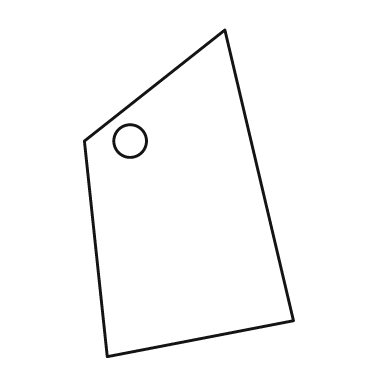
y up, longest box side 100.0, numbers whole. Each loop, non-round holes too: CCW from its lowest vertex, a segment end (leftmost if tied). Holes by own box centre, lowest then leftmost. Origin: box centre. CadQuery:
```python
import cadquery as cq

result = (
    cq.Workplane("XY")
    .moveTo(-25.0, -50.0)
    .lineTo(32.0, -39.0)
    .lineTo(11.0, 50.0)
    .lineTo(-32.0, 16.0)
    .close()
    .moveTo(-18.0, 16.0)
    .circle(5.0)
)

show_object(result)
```